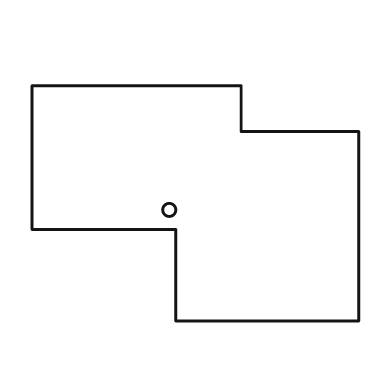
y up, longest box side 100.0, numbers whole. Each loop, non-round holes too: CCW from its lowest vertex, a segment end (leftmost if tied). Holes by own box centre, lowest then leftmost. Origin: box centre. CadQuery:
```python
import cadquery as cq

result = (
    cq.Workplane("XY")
    .moveTo(-6.0, -36.0)
    .lineTo(50.0, -36.0)
    .lineTo(50.0, 22.0)
    .lineTo(14.0, 22.0)
    .lineTo(14.0, 36.0)
    .lineTo(-50.0, 36.0)
    .lineTo(-50.0, -8.0)
    .lineTo(-6.0, -8.0)
    .close()
    .moveTo(-8.0, -2.0)
    .circle(2.0)
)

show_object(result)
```